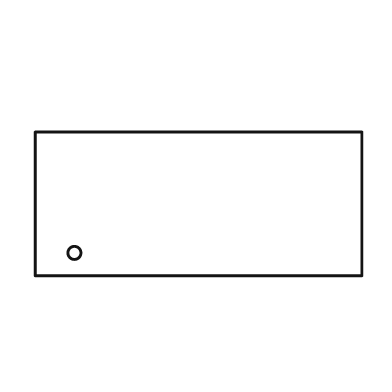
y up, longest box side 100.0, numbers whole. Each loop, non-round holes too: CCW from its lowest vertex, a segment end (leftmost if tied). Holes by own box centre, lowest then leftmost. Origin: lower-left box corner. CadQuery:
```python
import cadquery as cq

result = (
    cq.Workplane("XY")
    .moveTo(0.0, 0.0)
    .lineTo(100.0, 0.0)
    .lineTo(100.0, 44.0)
    .lineTo(0.0, 44.0)
    .close()
    .moveTo(12.0, 7.0)
    .circle(2.0)
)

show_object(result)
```